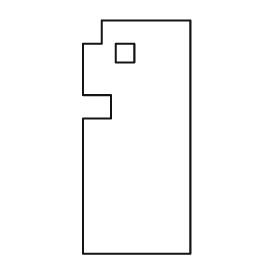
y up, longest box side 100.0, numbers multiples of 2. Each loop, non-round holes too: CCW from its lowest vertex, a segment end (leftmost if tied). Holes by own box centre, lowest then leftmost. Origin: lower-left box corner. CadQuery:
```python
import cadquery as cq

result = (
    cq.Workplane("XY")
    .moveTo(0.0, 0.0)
    .lineTo(46.0, 0.0)
    .lineTo(46.0, 100.0)
    .lineTo(8.0, 100.0)
    .lineTo(8.0, 90.0)
    .lineTo(0.0, 90.0)
    .lineTo(0.0, 68.0)
    .lineTo(12.0, 68.0)
    .lineTo(12.0, 58.0)
    .lineTo(0.0, 58.0)
    .close()
    .moveTo(14.0, 82.0)
    .lineTo(22.0, 82.0)
    .lineTo(22.0, 90.0)
    .lineTo(14.0, 90.0)
    .close()
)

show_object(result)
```